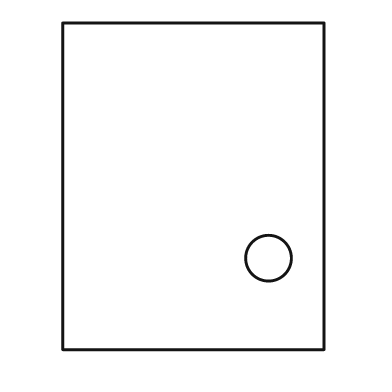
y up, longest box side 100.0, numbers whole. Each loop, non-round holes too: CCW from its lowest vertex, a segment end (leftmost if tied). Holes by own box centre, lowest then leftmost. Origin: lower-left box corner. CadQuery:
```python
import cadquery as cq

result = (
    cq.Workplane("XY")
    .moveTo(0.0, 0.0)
    .lineTo(80.0, 0.0)
    .lineTo(80.0, 100.0)
    .lineTo(0.0, 100.0)
    .close()
    .moveTo(63.0, 28.0)
    .circle(7.0)
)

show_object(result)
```